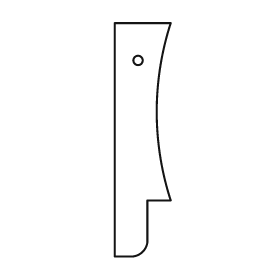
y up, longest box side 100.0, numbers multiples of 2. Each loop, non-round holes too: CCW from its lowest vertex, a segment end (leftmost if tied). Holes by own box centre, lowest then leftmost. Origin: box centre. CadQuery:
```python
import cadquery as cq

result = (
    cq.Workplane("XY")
    .moveTo(-12.0, -50.0)
    .lineTo(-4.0, -50.0)
    .threePointArc((0.0, -48.0), (2.0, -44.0))
    .lineTo(2.0, -26.0)
    .lineTo(12.0, -26.0)
    .threePointArc((6.0, 12.0), (12.0, 50.0))
    .lineTo(-12.0, 50.0)
    .close()
    .moveTo(-2.0, 34.0)
    .circle(2.0)
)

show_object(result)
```